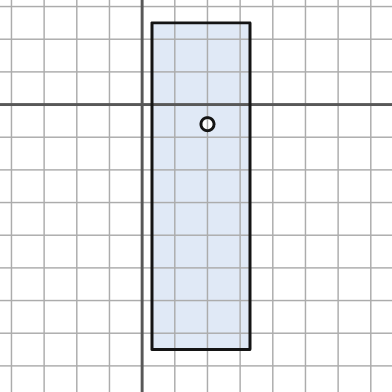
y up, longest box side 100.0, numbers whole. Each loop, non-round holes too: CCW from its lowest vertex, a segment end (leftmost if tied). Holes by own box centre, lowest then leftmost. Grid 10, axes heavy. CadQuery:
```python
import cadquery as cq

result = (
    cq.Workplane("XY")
    .moveTo(3.0, -75.0)
    .lineTo(33.0, -75.0)
    .lineTo(33.0, 25.0)
    .lineTo(3.0, 25.0)
    .close()
    .moveTo(20.0, -6.0)
    .circle(2.0)
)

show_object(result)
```